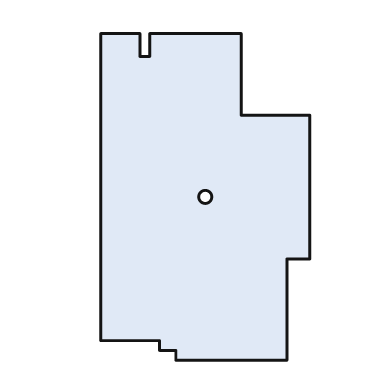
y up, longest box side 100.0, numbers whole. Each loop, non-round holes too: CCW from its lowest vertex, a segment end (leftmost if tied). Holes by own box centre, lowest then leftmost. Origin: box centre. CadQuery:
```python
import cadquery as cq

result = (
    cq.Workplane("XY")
    .moveTo(-9.0, -50.0)
    .lineTo(25.0, -50.0)
    .lineTo(25.0, -19.0)
    .lineTo(32.0, -19.0)
    .lineTo(32.0, 25.0)
    .lineTo(11.0, 25.0)
    .lineTo(11.0, 50.0)
    .lineTo(-17.0, 50.0)
    .lineTo(-17.0, 43.0)
    .lineTo(-20.0, 43.0)
    .lineTo(-20.0, 50.0)
    .lineTo(-32.0, 50.0)
    .lineTo(-32.0, -44.0)
    .lineTo(-14.0, -44.0)
    .lineTo(-14.0, -47.0)
    .lineTo(-9.0, -47.0)
    .close()
    .moveTo(0.0, 0.0)
    .circle(2.0)
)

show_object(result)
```